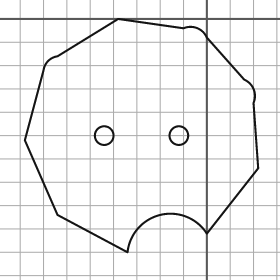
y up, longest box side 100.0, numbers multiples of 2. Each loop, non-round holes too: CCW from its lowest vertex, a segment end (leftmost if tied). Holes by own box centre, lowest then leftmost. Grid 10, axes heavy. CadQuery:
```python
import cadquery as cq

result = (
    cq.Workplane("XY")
    .moveTo(-34.0, -100.0)
    .threePointArc((-20.0, -84.0), (0.0, -92.0))
    .lineTo(22.0, -64.0)
    .lineTo(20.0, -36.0)
    .threePointArc((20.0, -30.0), (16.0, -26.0))
    .lineTo(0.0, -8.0)
    .threePointArc((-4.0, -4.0), (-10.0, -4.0))
    .lineTo(-38.0, 0.0)
    .lineTo(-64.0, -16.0)
    .threePointArc((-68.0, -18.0), (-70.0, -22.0))
    .lineTo(-78.0, -52.0)
    .lineTo(-64.0, -84.0)
    .close()
    .moveTo(-44.0, -50.0)
    .circle(4.0)
    .moveTo(-12.0, -50.0)
    .circle(4.0)
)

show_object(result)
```